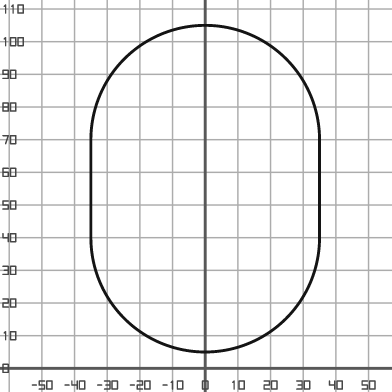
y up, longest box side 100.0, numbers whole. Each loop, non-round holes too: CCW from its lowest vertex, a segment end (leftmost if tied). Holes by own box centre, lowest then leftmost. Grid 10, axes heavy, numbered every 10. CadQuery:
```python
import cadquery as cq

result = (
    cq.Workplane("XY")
    .moveTo(-35.0, 40.0)
    .threePointArc((0.0, 5.0), (35.0, 40.0))
    .lineTo(35.0, 70.0)
    .threePointArc((0.0, 105.0), (-35.0, 70.0))
    .close()
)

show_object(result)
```